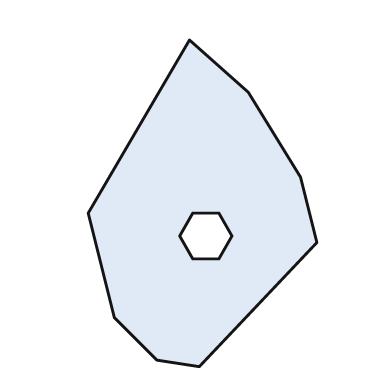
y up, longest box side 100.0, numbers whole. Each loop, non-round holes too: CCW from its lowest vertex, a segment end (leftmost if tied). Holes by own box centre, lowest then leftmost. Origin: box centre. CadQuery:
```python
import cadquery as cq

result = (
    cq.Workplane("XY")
    .moveTo(-1.0, -50.0)
    .lineTo(35.0, -12.0)
    .lineTo(30.0, 8.0)
    .lineTo(14.0, 34.0)
    .lineTo(-4.0, 50.0)
    .lineTo(-35.0, -3.0)
    .lineTo(-27.0, -35.0)
    .lineTo(-14.0, -48.0)
    .close()
    .moveTo(-3.0, -17.0)
    .lineTo(5.0, -17.0)
    .lineTo(9.0, -10.0)
    .lineTo(5.0, -3.0)
    .lineTo(-3.0, -3.0)
    .lineTo(-7.0, -10.0)
    .close()
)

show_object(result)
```